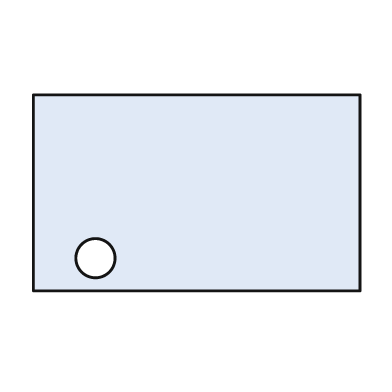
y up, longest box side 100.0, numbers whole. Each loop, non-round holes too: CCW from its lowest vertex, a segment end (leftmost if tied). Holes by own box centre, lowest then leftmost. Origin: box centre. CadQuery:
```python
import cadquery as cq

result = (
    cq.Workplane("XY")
    .moveTo(-50.0, -30.0)
    .lineTo(50.0, -30.0)
    .lineTo(50.0, 30.0)
    .lineTo(-50.0, 30.0)
    .close()
    .moveTo(-31.0, -20.0)
    .circle(6.0)
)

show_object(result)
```